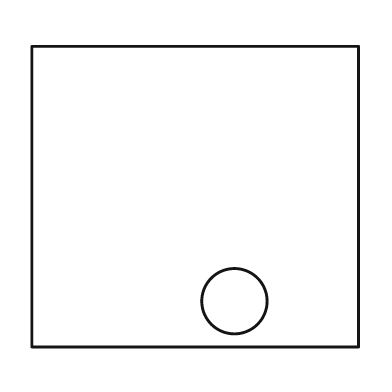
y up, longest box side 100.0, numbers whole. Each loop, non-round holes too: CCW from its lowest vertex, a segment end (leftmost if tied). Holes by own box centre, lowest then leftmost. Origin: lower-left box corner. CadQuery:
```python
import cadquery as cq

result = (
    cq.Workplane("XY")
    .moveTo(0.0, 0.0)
    .lineTo(100.0, 0.0)
    .lineTo(100.0, 92.0)
    .lineTo(0.0, 92.0)
    .close()
    .moveTo(62.0, 14.0)
    .circle(10.0)
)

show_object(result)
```